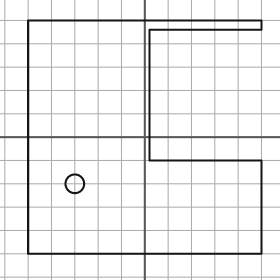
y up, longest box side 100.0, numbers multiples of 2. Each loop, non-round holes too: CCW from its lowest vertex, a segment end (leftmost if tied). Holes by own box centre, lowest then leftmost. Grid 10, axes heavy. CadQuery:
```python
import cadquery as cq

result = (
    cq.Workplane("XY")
    .moveTo(-50.0, -50.0)
    .lineTo(50.0, -50.0)
    .lineTo(50.0, -10.0)
    .lineTo(2.0, -10.0)
    .lineTo(2.0, 46.0)
    .lineTo(50.0, 46.0)
    .lineTo(50.0, 50.0)
    .lineTo(-50.0, 50.0)
    .close()
    .moveTo(-30.0, -20.0)
    .circle(4.0)
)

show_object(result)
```